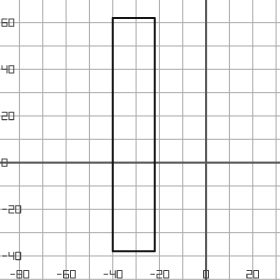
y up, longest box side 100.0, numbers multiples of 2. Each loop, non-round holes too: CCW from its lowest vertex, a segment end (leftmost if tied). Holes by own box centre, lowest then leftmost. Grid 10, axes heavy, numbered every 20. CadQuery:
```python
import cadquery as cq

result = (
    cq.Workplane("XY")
    .moveTo(-40.0, -38.0)
    .lineTo(-22.0, -38.0)
    .lineTo(-22.0, 62.0)
    .lineTo(-40.0, 62.0)
    .close()
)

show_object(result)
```